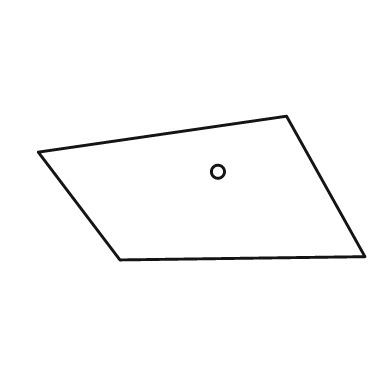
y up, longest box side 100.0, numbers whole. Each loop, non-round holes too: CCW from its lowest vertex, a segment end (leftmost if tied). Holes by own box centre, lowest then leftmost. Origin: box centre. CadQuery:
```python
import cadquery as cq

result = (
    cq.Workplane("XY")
    .moveTo(-25.0, -22.0)
    .lineTo(50.0, -21.0)
    .lineTo(26.0, 22.0)
    .lineTo(-50.0, 11.0)
    .close()
    .moveTo(5.0, 5.0)
    .circle(2.0)
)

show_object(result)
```